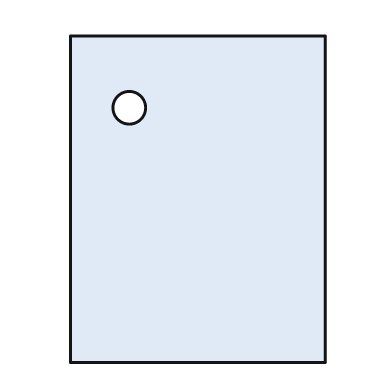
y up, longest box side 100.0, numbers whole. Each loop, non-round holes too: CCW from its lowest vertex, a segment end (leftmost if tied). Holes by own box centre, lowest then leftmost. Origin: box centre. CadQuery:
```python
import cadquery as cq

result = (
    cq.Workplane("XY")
    .moveTo(-39.0, -50.0)
    .lineTo(39.0, -50.0)
    .lineTo(39.0, 50.0)
    .lineTo(-39.0, 50.0)
    .close()
    .moveTo(-21.0, 28.0)
    .circle(5.0)
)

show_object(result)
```